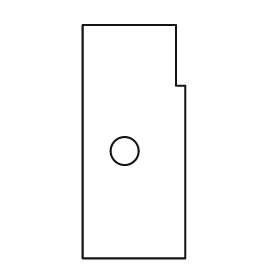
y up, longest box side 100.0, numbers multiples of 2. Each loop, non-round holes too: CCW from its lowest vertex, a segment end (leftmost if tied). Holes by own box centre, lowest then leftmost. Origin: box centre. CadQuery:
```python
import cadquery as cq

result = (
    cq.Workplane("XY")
    .moveTo(-22.0, -50.0)
    .lineTo(22.0, -50.0)
    .lineTo(22.0, 24.0)
    .lineTo(18.0, 24.0)
    .lineTo(18.0, 50.0)
    .lineTo(-22.0, 50.0)
    .close()
    .moveTo(-4.0, -4.0)
    .circle(6.0)
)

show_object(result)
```